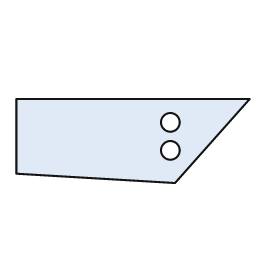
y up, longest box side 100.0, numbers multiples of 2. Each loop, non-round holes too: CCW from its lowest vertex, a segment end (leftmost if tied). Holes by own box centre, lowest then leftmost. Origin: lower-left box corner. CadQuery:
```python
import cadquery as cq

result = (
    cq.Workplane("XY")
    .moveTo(68.0, 0.0)
    .lineTo(100.0, 36.0)
    .lineTo(0.0, 36.0)
    .lineTo(0.0, 4.0)
    .close()
    .moveTo(66.0, 14.0)
    .circle(4.0)
    .moveTo(66.0, 26.0)
    .circle(4.0)
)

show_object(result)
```